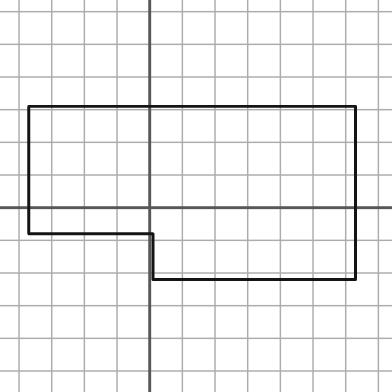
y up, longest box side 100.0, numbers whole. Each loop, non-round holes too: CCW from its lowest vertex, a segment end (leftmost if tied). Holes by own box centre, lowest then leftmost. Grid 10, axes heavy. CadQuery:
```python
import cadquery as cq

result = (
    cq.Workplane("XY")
    .moveTo(1.0, -22.0)
    .lineTo(63.0, -22.0)
    .lineTo(63.0, 31.0)
    .lineTo(-37.0, 31.0)
    .lineTo(-37.0, -8.0)
    .lineTo(1.0, -8.0)
    .close()
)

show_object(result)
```